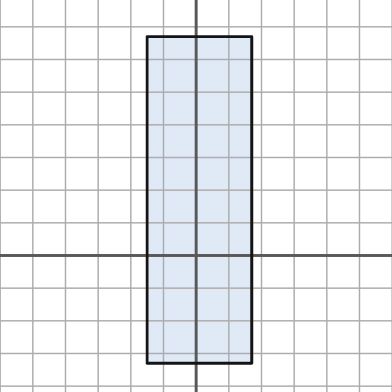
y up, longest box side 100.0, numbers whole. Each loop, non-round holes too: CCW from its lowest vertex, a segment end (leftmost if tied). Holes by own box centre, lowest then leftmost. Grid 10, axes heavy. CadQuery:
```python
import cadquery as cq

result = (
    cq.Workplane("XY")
    .moveTo(-15.0, -33.0)
    .lineTo(17.0, -33.0)
    .lineTo(17.0, 67.0)
    .lineTo(-15.0, 67.0)
    .close()
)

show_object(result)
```